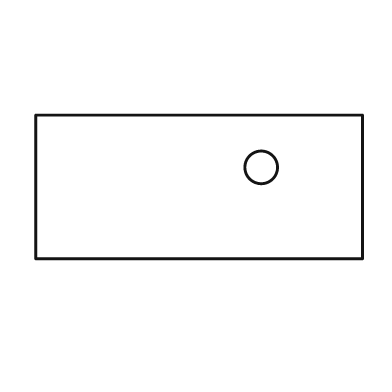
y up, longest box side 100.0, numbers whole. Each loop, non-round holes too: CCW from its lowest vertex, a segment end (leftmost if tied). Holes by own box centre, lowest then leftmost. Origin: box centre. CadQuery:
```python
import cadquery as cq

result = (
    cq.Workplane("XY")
    .moveTo(-50.0, -22.0)
    .lineTo(50.0, -22.0)
    .lineTo(50.0, 22.0)
    .lineTo(-50.0, 22.0)
    .close()
    .moveTo(19.0, 6.0)
    .circle(5.0)
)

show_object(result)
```